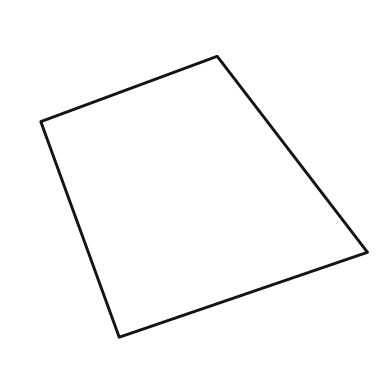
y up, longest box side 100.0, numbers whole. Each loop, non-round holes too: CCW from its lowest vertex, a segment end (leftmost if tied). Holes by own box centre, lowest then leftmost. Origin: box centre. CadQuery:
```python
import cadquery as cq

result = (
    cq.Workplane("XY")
    .moveTo(-26.0, -43.0)
    .lineTo(50.0, -17.0)
    .lineTo(4.0, 43.0)
    .lineTo(-50.0, 23.0)
    .close()
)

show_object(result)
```